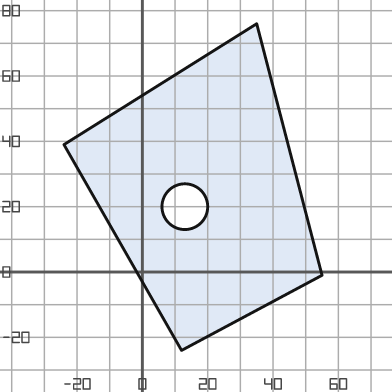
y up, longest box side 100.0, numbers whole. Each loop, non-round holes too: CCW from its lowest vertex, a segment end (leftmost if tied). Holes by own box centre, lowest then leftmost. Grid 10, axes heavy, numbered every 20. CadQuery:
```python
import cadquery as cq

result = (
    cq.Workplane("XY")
    .moveTo(12.0, -24.0)
    .lineTo(55.0, -1.0)
    .lineTo(35.0, 76.0)
    .lineTo(-24.0, 39.0)
    .close()
    .moveTo(13.0, 20.0)
    .circle(7.0)
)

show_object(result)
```